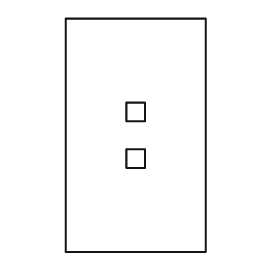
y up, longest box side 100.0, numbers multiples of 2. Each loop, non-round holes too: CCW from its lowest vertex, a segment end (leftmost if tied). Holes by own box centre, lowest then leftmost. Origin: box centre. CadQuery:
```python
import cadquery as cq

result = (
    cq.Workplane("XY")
    .moveTo(-30.0, -50.0)
    .lineTo(30.0, -50.0)
    .lineTo(30.0, 50.0)
    .lineTo(-30.0, 50.0)
    .close()
    .moveTo(-4.0, -14.0)
    .lineTo(4.0, -14.0)
    .lineTo(4.0, -6.0)
    .lineTo(-4.0, -6.0)
    .close()
    .moveTo(-4.0, 6.0)
    .lineTo(4.0, 6.0)
    .lineTo(4.0, 14.0)
    .lineTo(-4.0, 14.0)
    .close()
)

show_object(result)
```